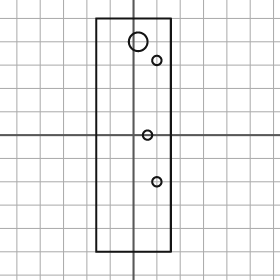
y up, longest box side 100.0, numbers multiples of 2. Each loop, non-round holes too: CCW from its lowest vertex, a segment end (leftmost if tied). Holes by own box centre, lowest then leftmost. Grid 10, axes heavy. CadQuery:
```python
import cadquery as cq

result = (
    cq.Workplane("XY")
    .moveTo(-16.0, -50.0)
    .lineTo(16.0, -50.0)
    .lineTo(16.0, 50.0)
    .lineTo(-16.0, 50.0)
    .close()
    .moveTo(10.0, -20.0)
    .circle(2.0)
    .moveTo(6.0, 0.0)
    .circle(2.0)
    .moveTo(10.0, 32.0)
    .circle(2.0)
    .moveTo(2.0, 40.0)
    .circle(4.0)
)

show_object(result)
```